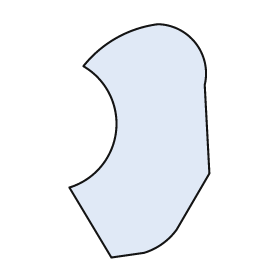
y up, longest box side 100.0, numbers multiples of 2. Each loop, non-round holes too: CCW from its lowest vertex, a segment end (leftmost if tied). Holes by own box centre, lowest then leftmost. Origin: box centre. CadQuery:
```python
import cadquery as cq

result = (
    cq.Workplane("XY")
    .moveTo(-12.0, -50.0)
    .lineTo(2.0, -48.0)
    .threePointArc((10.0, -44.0), (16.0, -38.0))
    .lineTo(30.0, -14.0)
    .lineTo(28.0, 24.0)
    .threePointArc((24.0, 42.0), (8.0, 50.0))
    .threePointArc((-10.0, 44.0), (-24.0, 32.0))
    .threePointArc((-10.0, 4.0), (-30.0, -20.0))
    .close()
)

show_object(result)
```